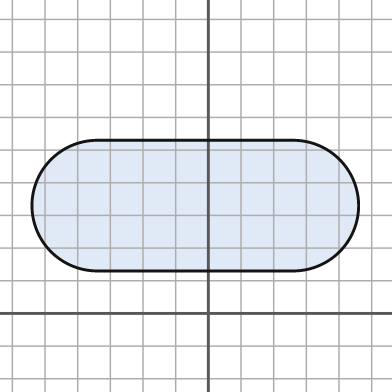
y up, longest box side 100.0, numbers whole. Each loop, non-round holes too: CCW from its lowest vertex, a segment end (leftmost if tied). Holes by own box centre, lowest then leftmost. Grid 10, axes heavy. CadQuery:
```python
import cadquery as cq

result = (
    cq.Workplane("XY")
    .moveTo(-34.0, 13.0)
    .lineTo(26.0, 13.0)
    .threePointArc((46.0, 33.0), (26.0, 53.0))
    .lineTo(-34.0, 53.0)
    .threePointArc((-54.0, 33.0), (-34.0, 13.0))
    .close()
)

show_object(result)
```